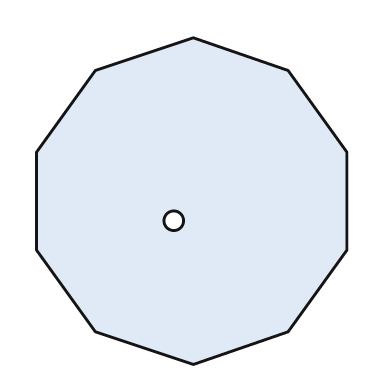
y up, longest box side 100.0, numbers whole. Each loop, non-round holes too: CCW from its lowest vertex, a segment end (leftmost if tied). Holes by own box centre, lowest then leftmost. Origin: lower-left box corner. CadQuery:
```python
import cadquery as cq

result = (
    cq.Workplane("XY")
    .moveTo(48.0, 0.0)
    .lineTo(77.0, 10.0)
    .lineTo(95.0, 35.0)
    .lineTo(95.0, 65.0)
    .lineTo(77.0, 90.0)
    .lineTo(48.0, 100.0)
    .lineTo(18.0, 90.0)
    .lineTo(0.0, 65.0)
    .lineTo(0.0, 35.0)
    .lineTo(18.0, 10.0)
    .close()
    .moveTo(42.0, 44.0)
    .circle(3.0)
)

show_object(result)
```